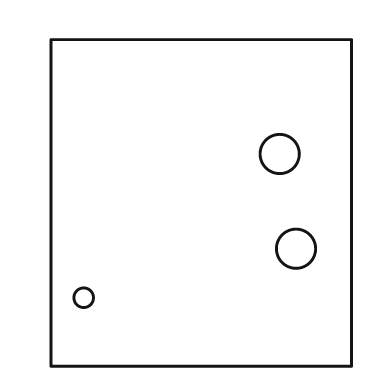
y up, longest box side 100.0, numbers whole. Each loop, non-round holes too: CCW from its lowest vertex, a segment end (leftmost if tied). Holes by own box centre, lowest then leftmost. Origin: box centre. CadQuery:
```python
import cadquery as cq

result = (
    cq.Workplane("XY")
    .moveTo(-46.0, -50.0)
    .lineTo(46.0, -50.0)
    .lineTo(46.0, 50.0)
    .lineTo(-46.0, 50.0)
    .close()
    .moveTo(-36.0, -29.0)
    .circle(3.0)
    .moveTo(29.0, -14.0)
    .circle(6.0)
    .moveTo(24.0, 15.0)
    .circle(6.0)
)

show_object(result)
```